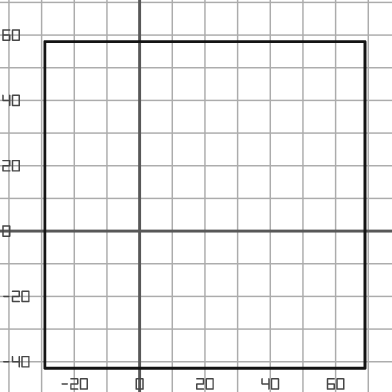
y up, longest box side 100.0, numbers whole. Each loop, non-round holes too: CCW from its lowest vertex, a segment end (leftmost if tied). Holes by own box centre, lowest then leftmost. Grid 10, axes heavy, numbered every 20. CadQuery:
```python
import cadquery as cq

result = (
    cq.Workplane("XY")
    .moveTo(-29.0, -42.0)
    .lineTo(69.0, -42.0)
    .lineTo(69.0, 58.0)
    .lineTo(-29.0, 58.0)
    .close()
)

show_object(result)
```